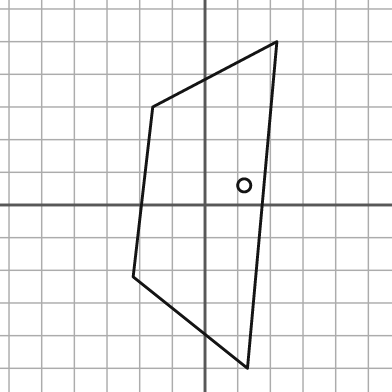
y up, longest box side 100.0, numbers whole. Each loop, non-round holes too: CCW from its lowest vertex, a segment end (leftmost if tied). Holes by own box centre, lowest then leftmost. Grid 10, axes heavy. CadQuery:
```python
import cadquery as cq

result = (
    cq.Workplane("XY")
    .moveTo(13.0, -50.0)
    .lineTo(22.0, 50.0)
    .lineTo(-16.0, 30.0)
    .lineTo(-22.0, -22.0)
    .close()
    .moveTo(12.0, 6.0)
    .circle(2.0)
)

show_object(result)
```